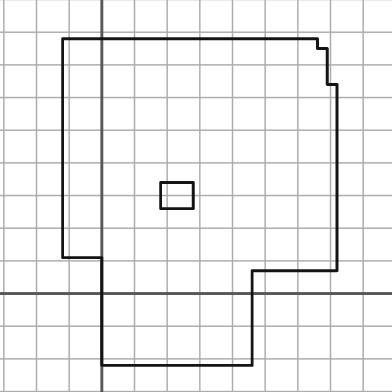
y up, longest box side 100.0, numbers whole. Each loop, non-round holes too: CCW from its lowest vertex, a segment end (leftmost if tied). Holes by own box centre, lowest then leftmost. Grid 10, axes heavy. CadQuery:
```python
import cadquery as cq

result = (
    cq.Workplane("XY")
    .moveTo(0.0, -22.0)
    .lineTo(46.0, -22.0)
    .lineTo(46.0, 7.0)
    .lineTo(72.0, 7.0)
    .lineTo(72.0, 64.0)
    .lineTo(69.0, 64.0)
    .lineTo(69.0, 75.0)
    .lineTo(66.0, 75.0)
    .lineTo(66.0, 78.0)
    .lineTo(-12.0, 78.0)
    .lineTo(-12.0, 11.0)
    .lineTo(0.0, 11.0)
    .close()
    .moveTo(18.0, 26.0)
    .lineTo(28.0, 26.0)
    .lineTo(28.0, 34.0)
    .lineTo(18.0, 34.0)
    .close()
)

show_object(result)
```